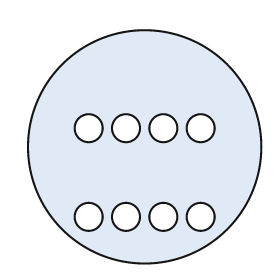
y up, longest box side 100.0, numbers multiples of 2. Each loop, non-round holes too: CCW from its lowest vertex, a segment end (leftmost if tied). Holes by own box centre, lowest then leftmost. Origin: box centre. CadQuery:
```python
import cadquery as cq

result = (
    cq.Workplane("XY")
    .moveTo(0.0, 0.0)
    .circle(50.0)
    .moveTo(-24.0, -30.0)
    .circle(6.0)
    .moveTo(-8.0, -30.0)
    .circle(6.0)
    .moveTo(8.0, -30.0)
    .circle(6.0)
    .moveTo(24.0, -30.0)
    .circle(6.0)
    .moveTo(-24.0, 8.0)
    .circle(6.0)
    .moveTo(-8.0, 8.0)
    .circle(6.0)
    .moveTo(8.0, 8.0)
    .circle(6.0)
    .moveTo(24.0, 8.0)
    .circle(6.0)
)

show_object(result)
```